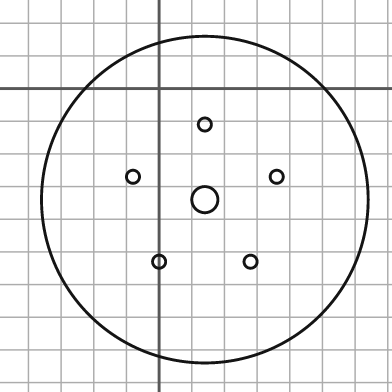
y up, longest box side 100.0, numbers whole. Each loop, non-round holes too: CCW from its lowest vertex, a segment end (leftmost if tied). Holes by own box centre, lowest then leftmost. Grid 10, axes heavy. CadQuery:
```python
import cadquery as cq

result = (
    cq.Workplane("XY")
    .moveTo(14.0, -34.0)
    .circle(50.0)
    .moveTo(0.0, -53.0)
    .circle(2.0)
    .moveTo(28.0, -53.0)
    .circle(2.0)
    .moveTo(14.0, -34.0)
    .circle(4.0)
    .moveTo(-8.0, -27.0)
    .circle(2.0)
    .moveTo(36.0, -27.0)
    .circle(2.0)
    .moveTo(14.0, -11.0)
    .circle(2.0)
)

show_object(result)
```